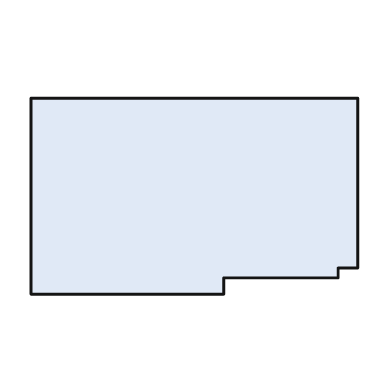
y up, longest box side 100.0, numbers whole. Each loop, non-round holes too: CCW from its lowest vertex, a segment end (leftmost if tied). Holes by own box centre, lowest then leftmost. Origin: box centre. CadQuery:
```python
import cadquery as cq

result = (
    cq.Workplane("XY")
    .moveTo(-50.0, -30.0)
    .lineTo(9.0, -30.0)
    .lineTo(9.0, -25.0)
    .lineTo(44.0, -25.0)
    .lineTo(44.0, -22.0)
    .lineTo(50.0, -22.0)
    .lineTo(50.0, 30.0)
    .lineTo(-50.0, 30.0)
    .close()
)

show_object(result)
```